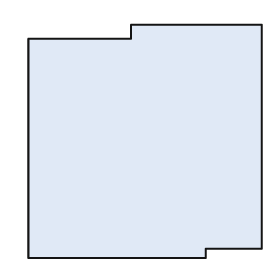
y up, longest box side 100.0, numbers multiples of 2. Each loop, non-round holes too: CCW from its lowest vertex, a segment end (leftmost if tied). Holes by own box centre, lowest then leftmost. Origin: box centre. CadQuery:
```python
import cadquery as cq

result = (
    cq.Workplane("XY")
    .moveTo(-50.0, -50.0)
    .lineTo(26.0, -50.0)
    .lineTo(26.0, -46.0)
    .lineTo(50.0, -46.0)
    .lineTo(50.0, 50.0)
    .lineTo(-6.0, 50.0)
    .lineTo(-6.0, 44.0)
    .lineTo(-50.0, 44.0)
    .close()
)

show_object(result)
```